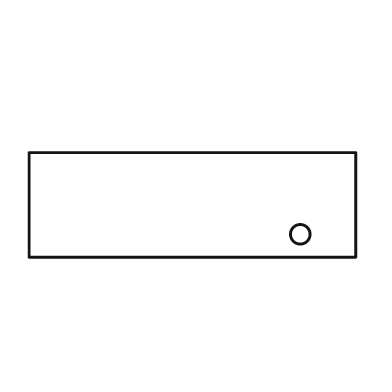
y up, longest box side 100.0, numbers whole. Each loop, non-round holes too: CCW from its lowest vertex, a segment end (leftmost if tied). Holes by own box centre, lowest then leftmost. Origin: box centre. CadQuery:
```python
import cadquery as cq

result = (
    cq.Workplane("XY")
    .moveTo(-50.0, -16.0)
    .lineTo(50.0, -16.0)
    .lineTo(50.0, 16.0)
    .lineTo(-50.0, 16.0)
    .close()
    .moveTo(33.0, -9.0)
    .circle(3.0)
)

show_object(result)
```